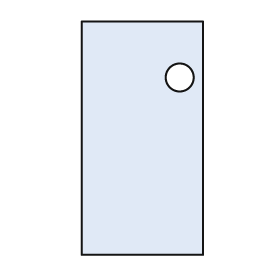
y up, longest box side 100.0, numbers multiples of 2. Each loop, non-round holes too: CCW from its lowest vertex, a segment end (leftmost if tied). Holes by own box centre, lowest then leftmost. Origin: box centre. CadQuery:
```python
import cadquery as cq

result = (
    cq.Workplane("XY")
    .moveTo(-26.0, -50.0)
    .lineTo(26.0, -50.0)
    .lineTo(26.0, 50.0)
    .lineTo(-26.0, 50.0)
    .close()
    .moveTo(16.0, 26.0)
    .circle(6.0)
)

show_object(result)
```